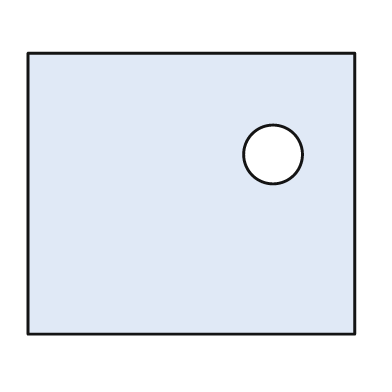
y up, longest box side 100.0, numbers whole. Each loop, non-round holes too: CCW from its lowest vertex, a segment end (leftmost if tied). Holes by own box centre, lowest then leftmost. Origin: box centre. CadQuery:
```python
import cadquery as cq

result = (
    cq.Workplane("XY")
    .moveTo(-50.0, -43.0)
    .lineTo(50.0, -43.0)
    .lineTo(50.0, 43.0)
    .lineTo(-50.0, 43.0)
    .close()
    .moveTo(25.0, 12.0)
    .circle(9.0)
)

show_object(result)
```